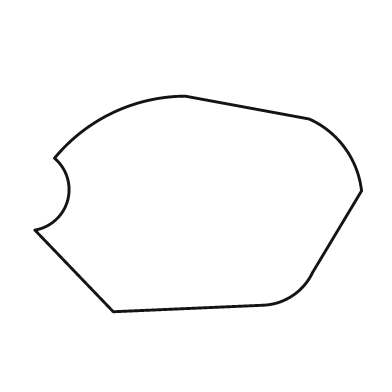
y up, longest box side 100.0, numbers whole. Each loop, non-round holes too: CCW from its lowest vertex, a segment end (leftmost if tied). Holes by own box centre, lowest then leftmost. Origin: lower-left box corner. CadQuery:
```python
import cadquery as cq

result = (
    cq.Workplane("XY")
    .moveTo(24.0, 0.0)
    .lineTo(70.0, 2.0)
    .threePointArc((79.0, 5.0), (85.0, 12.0))
    .lineTo(100.0, 37.0)
    .threePointArc((95.0, 50.0), (84.0, 59.0))
    .lineTo(46.0, 66.0)
    .threePointArc((24.0, 61.0), (6.0, 47.0))
    .threePointArc((10.0, 34.0), (0.0, 25.0))
    .close()
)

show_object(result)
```